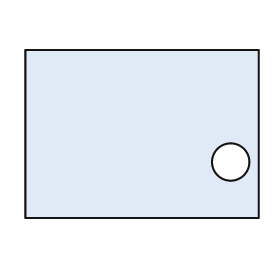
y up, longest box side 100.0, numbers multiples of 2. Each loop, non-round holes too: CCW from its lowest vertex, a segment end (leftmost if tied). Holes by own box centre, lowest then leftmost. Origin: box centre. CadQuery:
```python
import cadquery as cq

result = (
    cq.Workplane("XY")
    .moveTo(-50.0, -36.0)
    .lineTo(50.0, -36.0)
    .lineTo(50.0, 36.0)
    .lineTo(-50.0, 36.0)
    .close()
    .moveTo(38.0, -12.0)
    .circle(8.0)
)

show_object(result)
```